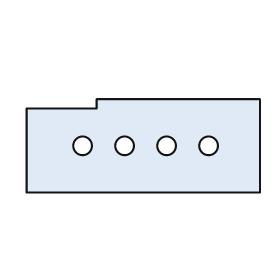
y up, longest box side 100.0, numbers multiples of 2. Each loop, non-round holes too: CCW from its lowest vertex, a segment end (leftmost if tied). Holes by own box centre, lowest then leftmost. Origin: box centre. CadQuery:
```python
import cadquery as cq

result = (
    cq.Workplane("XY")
    .moveTo(-50.0, -20.0)
    .lineTo(50.0, -20.0)
    .lineTo(50.0, 20.0)
    .lineTo(-20.0, 20.0)
    .lineTo(-20.0, 16.0)
    .lineTo(-50.0, 16.0)
    .close()
    .moveTo(-26.0, 0.0)
    .circle(4.0)
    .moveTo(-8.0, 0.0)
    .circle(4.0)
    .moveTo(10.0, 0.0)
    .circle(4.0)
    .moveTo(28.0, 0.0)
    .circle(4.0)
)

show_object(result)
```